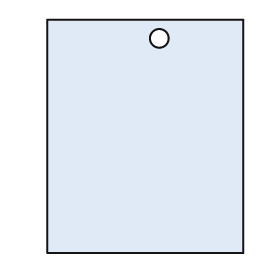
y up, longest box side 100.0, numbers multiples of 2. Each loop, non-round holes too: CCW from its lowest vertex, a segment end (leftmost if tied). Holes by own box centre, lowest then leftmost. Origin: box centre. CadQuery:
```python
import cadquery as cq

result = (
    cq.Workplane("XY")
    .moveTo(-42.0, -50.0)
    .lineTo(42.0, -50.0)
    .lineTo(42.0, 50.0)
    .lineTo(-42.0, 50.0)
    .close()
    .moveTo(6.0, 42.0)
    .circle(4.0)
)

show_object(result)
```